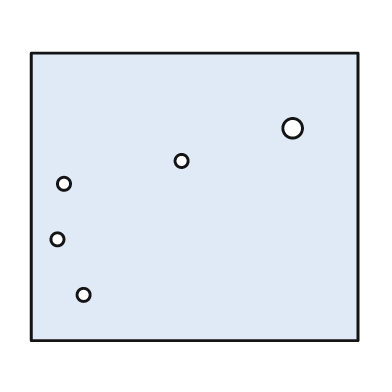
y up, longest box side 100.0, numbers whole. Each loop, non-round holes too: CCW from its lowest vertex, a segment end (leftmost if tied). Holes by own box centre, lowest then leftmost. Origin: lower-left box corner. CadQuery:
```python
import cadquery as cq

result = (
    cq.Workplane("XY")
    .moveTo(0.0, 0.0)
    .lineTo(100.0, 0.0)
    .lineTo(100.0, 88.0)
    .lineTo(0.0, 88.0)
    .close()
    .moveTo(16.0, 14.0)
    .circle(2.0)
    .moveTo(8.0, 31.0)
    .circle(2.0)
    .moveTo(10.0, 48.0)
    .circle(2.0)
    .moveTo(46.0, 55.0)
    .circle(2.0)
    .moveTo(80.0, 65.0)
    .circle(3.0)
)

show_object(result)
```